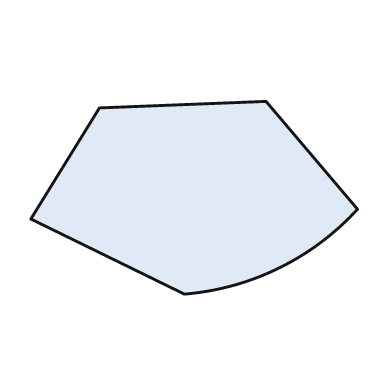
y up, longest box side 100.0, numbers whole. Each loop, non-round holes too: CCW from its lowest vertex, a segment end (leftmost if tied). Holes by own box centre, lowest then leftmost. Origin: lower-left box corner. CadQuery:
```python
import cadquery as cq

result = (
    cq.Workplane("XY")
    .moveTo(47.0, 0.0)
    .threePointArc((76.0, 8.0), (100.0, 26.0))
    .lineTo(72.0, 59.0)
    .lineTo(21.0, 57.0)
    .lineTo(0.0, 23.0)
    .close()
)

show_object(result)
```